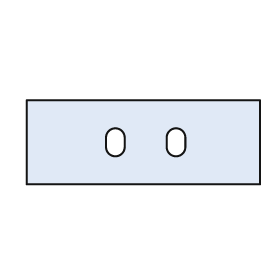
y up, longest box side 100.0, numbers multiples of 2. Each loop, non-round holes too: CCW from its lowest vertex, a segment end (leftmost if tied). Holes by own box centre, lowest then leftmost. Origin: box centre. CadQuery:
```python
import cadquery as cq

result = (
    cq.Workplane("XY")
    .moveTo(-50.0, -18.0)
    .lineTo(50.0, -18.0)
    .lineTo(50.0, 18.0)
    .lineTo(-50.0, 18.0)
    .close()
    .moveTo(-16.0, -2.0)
    .threePointArc((-12.0, -6.0), (-8.0, -2.0))
    .lineTo(-8.0, 2.0)
    .threePointArc((-12.0, 6.0), (-16.0, 2.0))
    .close()
    .moveTo(10.0, -2.0)
    .threePointArc((14.0, -6.0), (18.0, -2.0))
    .lineTo(18.0, 2.0)
    .threePointArc((14.0, 6.0), (10.0, 2.0))
    .close()
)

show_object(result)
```